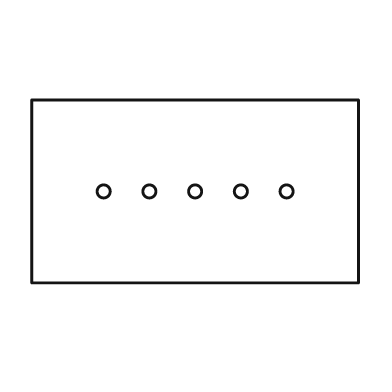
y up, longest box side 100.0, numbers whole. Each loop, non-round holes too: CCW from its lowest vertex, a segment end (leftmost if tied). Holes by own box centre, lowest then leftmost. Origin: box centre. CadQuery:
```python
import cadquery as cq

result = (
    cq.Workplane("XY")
    .moveTo(-50.0, -28.0)
    .lineTo(50.0, -28.0)
    .lineTo(50.0, 28.0)
    .lineTo(-50.0, 28.0)
    .close()
    .moveTo(-28.0, 0.0)
    .circle(2.0)
    .moveTo(-14.0, 0.0)
    .circle(2.0)
    .moveTo(0.0, 0.0)
    .circle(2.0)
    .moveTo(14.0, 0.0)
    .circle(2.0)
    .moveTo(28.0, 0.0)
    .circle(2.0)
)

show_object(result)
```